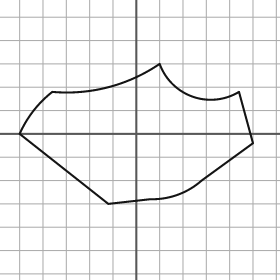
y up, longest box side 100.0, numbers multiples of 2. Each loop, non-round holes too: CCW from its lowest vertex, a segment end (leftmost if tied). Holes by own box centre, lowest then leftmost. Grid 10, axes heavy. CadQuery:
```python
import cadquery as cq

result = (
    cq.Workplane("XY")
    .moveTo(-12.0, -30.0)
    .lineTo(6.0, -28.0)
    .threePointArc((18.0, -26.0), (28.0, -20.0))
    .lineTo(50.0, -4.0)
    .lineTo(44.0, 18.0)
    .threePointArc((24.0, 16.0), (10.0, 30.0))
    .threePointArc((-12.0, 20.0), (-36.0, 18.0))
    .threePointArc((-44.0, 10.0), (-50.0, 0.0))
    .close()
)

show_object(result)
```